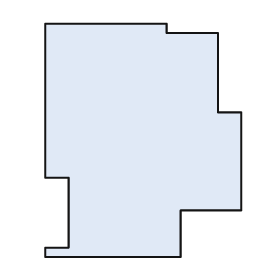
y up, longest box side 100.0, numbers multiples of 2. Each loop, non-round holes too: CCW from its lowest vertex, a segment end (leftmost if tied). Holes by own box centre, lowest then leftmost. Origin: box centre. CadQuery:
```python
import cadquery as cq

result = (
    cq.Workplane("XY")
    .moveTo(-42.0, -50.0)
    .lineTo(16.0, -50.0)
    .lineTo(16.0, -30.0)
    .lineTo(42.0, -30.0)
    .lineTo(42.0, 12.0)
    .lineTo(32.0, 12.0)
    .lineTo(32.0, 46.0)
    .lineTo(10.0, 46.0)
    .lineTo(10.0, 50.0)
    .lineTo(-42.0, 50.0)
    .lineTo(-42.0, -16.0)
    .lineTo(-32.0, -16.0)
    .lineTo(-32.0, -46.0)
    .lineTo(-42.0, -46.0)
    .close()
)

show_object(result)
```